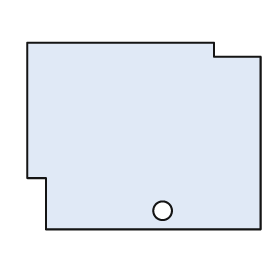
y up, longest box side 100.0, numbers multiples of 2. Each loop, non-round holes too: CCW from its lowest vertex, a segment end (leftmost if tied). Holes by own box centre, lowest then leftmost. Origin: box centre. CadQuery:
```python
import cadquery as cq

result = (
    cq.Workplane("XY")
    .moveTo(-42.0, -40.0)
    .lineTo(50.0, -40.0)
    .lineTo(50.0, 34.0)
    .lineTo(30.0, 34.0)
    .lineTo(30.0, 40.0)
    .lineTo(-50.0, 40.0)
    .lineTo(-50.0, -18.0)
    .lineTo(-42.0, -18.0)
    .close()
    .moveTo(8.0, -32.0)
    .circle(4.0)
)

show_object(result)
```